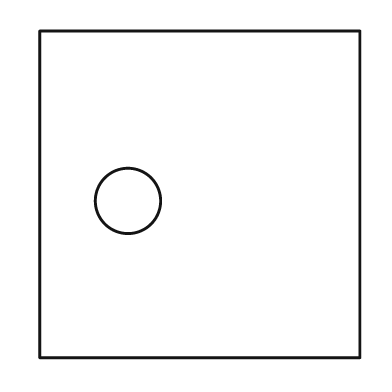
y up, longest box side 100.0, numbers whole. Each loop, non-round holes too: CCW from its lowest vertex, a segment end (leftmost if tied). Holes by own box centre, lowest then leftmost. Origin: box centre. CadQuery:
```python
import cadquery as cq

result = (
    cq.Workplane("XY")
    .moveTo(-49.0, -50.0)
    .lineTo(49.0, -50.0)
    .lineTo(49.0, 50.0)
    .lineTo(-49.0, 50.0)
    .close()
    .moveTo(-22.0, -2.0)
    .circle(10.0)
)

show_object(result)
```